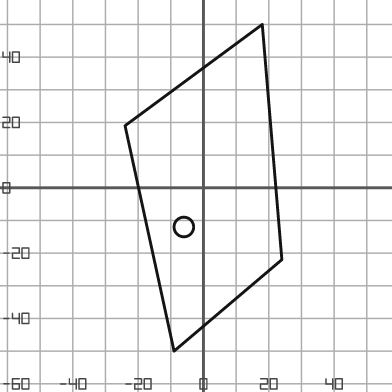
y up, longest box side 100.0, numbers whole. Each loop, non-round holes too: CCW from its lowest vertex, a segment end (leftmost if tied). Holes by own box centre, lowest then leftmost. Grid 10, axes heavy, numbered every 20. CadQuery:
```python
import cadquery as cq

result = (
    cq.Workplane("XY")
    .moveTo(-9.0, -50.0)
    .lineTo(24.0, -22.0)
    .lineTo(18.0, 50.0)
    .lineTo(-24.0, 19.0)
    .close()
    .moveTo(-6.0, -12.0)
    .circle(3.0)
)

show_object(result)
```